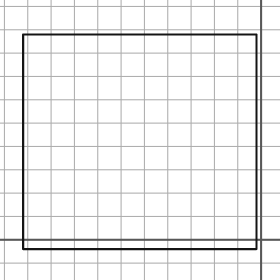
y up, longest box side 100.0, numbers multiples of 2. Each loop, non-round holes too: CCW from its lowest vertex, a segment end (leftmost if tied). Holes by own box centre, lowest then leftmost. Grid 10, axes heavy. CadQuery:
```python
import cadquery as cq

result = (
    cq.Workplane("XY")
    .moveTo(-102.0, -4.0)
    .lineTo(-2.0, -4.0)
    .lineTo(-2.0, 88.0)
    .lineTo(-102.0, 88.0)
    .close()
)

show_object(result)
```